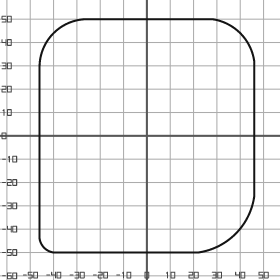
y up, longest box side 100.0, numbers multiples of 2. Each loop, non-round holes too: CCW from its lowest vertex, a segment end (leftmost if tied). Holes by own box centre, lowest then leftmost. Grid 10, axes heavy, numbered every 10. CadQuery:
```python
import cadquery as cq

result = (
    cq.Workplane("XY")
    .moveTo(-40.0, -50.0)
    .lineTo(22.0, -50.0)
    .threePointArc((38.0, -42.0), (46.0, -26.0))
    .lineTo(46.0, 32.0)
    .threePointArc((40.0, 44.0), (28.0, 50.0))
    .lineTo(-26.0, 50.0)
    .threePointArc((-40.0, 44.0), (-46.0, 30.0))
    .lineTo(-46.0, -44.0)
    .threePointArc((-44.0, -48.0), (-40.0, -50.0))
    .close()
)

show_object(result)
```